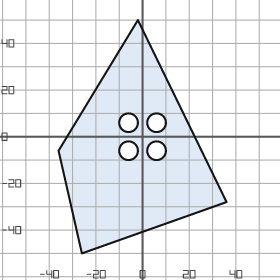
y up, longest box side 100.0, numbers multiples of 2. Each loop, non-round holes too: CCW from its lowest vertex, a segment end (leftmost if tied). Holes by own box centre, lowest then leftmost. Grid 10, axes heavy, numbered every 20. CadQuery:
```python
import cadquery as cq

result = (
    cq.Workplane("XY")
    .moveTo(-26.0, -50.0)
    .lineTo(36.0, -28.0)
    .lineTo(-2.0, 50.0)
    .lineTo(-36.0, -6.0)
    .close()
    .moveTo(-6.0, -6.0)
    .circle(4.0)
    .moveTo(6.0, -6.0)
    .circle(4.0)
    .moveTo(-6.0, 6.0)
    .circle(4.0)
    .moveTo(6.0, 6.0)
    .circle(4.0)
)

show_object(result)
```